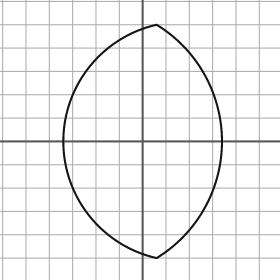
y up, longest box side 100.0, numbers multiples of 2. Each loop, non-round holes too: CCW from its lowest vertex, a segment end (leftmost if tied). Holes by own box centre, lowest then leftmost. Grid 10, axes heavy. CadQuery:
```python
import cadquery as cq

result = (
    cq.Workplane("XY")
    .moveTo(6.0, -50.0)
    .threePointArc((34.0, 0.0), (6.0, 50.0))
    .threePointArc((-34.0, 0.0), (6.0, -50.0))
    .close()
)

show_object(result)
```